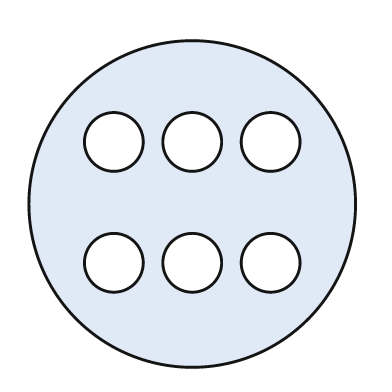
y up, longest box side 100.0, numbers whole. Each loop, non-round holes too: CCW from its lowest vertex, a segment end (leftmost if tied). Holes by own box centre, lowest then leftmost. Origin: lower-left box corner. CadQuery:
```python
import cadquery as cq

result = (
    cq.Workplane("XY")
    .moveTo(50.0, 50.0)
    .circle(50.0)
    .moveTo(26.0, 32.0)
    .circle(9.0)
    .moveTo(50.0, 32.0)
    .circle(9.0)
    .moveTo(74.0, 32.0)
    .circle(9.0)
    .moveTo(26.0, 69.0)
    .circle(9.0)
    .moveTo(50.0, 69.0)
    .circle(9.0)
    .moveTo(74.0, 69.0)
    .circle(9.0)
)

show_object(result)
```